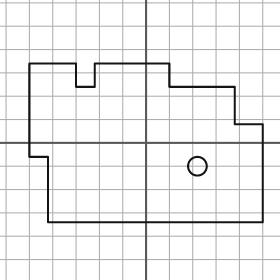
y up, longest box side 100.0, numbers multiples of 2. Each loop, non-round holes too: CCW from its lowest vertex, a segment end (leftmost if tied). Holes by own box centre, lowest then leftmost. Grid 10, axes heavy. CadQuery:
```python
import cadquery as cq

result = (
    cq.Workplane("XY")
    .moveTo(-42.0, -34.0)
    .lineTo(50.0, -34.0)
    .lineTo(50.0, 8.0)
    .lineTo(38.0, 8.0)
    .lineTo(38.0, 24.0)
    .lineTo(10.0, 24.0)
    .lineTo(10.0, 34.0)
    .lineTo(-22.0, 34.0)
    .lineTo(-22.0, 24.0)
    .lineTo(-30.0, 24.0)
    .lineTo(-30.0, 34.0)
    .lineTo(-50.0, 34.0)
    .lineTo(-50.0, -6.0)
    .lineTo(-42.0, -6.0)
    .close()
    .moveTo(22.0, -10.0)
    .circle(4.0)
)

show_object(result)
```